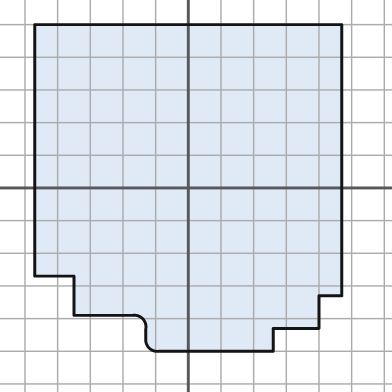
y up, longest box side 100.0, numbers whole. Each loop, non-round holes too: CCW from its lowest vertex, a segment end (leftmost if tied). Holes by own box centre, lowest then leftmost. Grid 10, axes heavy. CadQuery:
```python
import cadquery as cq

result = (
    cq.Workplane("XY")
    .moveTo(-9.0, -50.0)
    .lineTo(26.0, -50.0)
    .lineTo(26.0, -43.0)
    .lineTo(40.0, -43.0)
    .lineTo(40.0, -33.0)
    .lineTo(47.0, -33.0)
    .lineTo(47.0, 50.0)
    .lineTo(-47.0, 50.0)
    .lineTo(-47.0, -27.0)
    .lineTo(-35.0, -27.0)
    .lineTo(-35.0, -39.0)
    .lineTo(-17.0, -39.0)
    .threePointArc((-14.0, -40.0), (-13.0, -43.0))
    .lineTo(-13.0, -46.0)
    .threePointArc((-12.0, -49.0), (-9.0, -50.0))
    .close()
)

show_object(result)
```